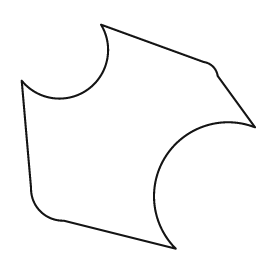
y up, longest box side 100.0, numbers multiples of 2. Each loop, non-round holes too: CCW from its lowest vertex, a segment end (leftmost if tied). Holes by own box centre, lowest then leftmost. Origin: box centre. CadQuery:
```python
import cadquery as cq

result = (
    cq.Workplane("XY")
    .moveTo(16.0, -48.0)
    .threePointArc((12.0, -8.0), (50.0, 4.0))
    .lineTo(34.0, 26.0)
    .threePointArc((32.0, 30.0), (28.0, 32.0))
    .lineTo(-16.0, 48.0)
    .threePointArc((-22.0, 20.0), (-50.0, 24.0))
    .lineTo(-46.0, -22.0)
    .threePointArc((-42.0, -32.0), (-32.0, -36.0))
    .close()
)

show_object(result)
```